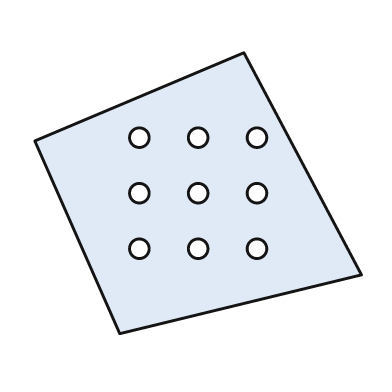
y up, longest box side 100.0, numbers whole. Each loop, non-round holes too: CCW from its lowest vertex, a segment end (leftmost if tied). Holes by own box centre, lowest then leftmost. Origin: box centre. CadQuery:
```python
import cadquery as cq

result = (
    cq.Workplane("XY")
    .moveTo(-24.0, -43.0)
    .lineTo(50.0, -25.0)
    .lineTo(14.0, 43.0)
    .lineTo(-50.0, 16.0)
    .close()
    .moveTo(-18.0, -17.0)
    .circle(3.0)
    .moveTo(0.0, -17.0)
    .circle(3.0)
    .moveTo(18.0, -17.0)
    .circle(3.0)
    .moveTo(-18.0, 0.0)
    .circle(3.0)
    .moveTo(0.0, 0.0)
    .circle(3.0)
    .moveTo(18.0, 0.0)
    .circle(3.0)
    .moveTo(-18.0, 17.0)
    .circle(3.0)
    .moveTo(0.0, 17.0)
    .circle(3.0)
    .moveTo(18.0, 17.0)
    .circle(3.0)
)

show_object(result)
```